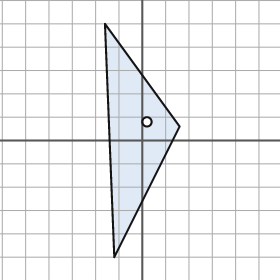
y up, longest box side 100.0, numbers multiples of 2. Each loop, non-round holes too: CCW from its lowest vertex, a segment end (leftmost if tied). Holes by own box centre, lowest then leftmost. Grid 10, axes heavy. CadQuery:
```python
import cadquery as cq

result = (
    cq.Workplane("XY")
    .moveTo(-12.0, -50.0)
    .lineTo(16.0, 6.0)
    .lineTo(-16.0, 50.0)
    .close()
    .moveTo(2.0, 8.0)
    .circle(2.0)
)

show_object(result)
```